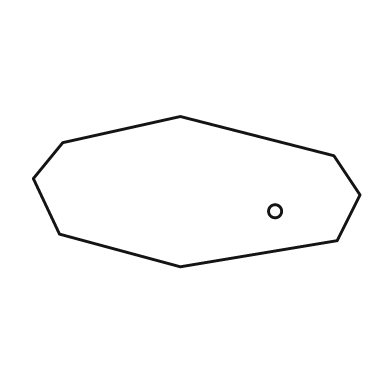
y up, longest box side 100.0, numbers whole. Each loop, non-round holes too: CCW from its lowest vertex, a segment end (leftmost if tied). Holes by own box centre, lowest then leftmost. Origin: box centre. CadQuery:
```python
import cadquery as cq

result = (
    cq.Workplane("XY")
    .moveTo(-5.0, -23.0)
    .lineTo(43.0, -15.0)
    .lineTo(50.0, -1.0)
    .lineTo(42.0, 11.0)
    .lineTo(-5.0, 23.0)
    .lineTo(-41.0, 15.0)
    .lineTo(-50.0, 4.0)
    .lineTo(-42.0, -13.0)
    .close()
    .moveTo(24.0, -6.0)
    .circle(2.0)
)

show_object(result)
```